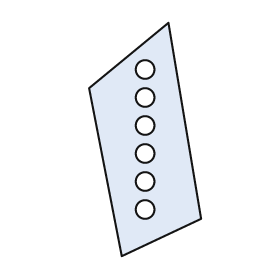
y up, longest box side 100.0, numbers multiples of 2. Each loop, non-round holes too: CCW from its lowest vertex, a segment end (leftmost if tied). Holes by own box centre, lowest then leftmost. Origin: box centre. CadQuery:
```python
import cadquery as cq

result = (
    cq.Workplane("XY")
    .moveTo(-10.0, -50.0)
    .lineTo(24.0, -34.0)
    .lineTo(10.0, 50.0)
    .lineTo(-24.0, 22.0)
    .close()
    .moveTo(0.0, -30.0)
    .circle(4.0)
    .moveTo(0.0, -18.0)
    .circle(4.0)
    .moveTo(0.0, -6.0)
    .circle(4.0)
    .moveTo(0.0, 6.0)
    .circle(4.0)
    .moveTo(0.0, 18.0)
    .circle(4.0)
    .moveTo(0.0, 30.0)
    .circle(4.0)
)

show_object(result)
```